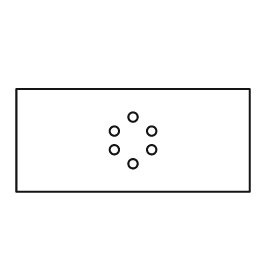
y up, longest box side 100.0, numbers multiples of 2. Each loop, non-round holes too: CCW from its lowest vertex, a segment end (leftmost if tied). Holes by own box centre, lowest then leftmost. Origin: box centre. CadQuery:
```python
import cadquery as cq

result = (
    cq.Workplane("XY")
    .moveTo(-50.0, -22.0)
    .lineTo(50.0, -22.0)
    .lineTo(50.0, 22.0)
    .lineTo(-50.0, 22.0)
    .close()
    .moveTo(0.0, -10.0)
    .circle(2.0)
    .moveTo(-8.0, -4.0)
    .circle(2.0)
    .moveTo(8.0, -4.0)
    .circle(2.0)
    .moveTo(-8.0, 4.0)
    .circle(2.0)
    .moveTo(8.0, 4.0)
    .circle(2.0)
    .moveTo(0.0, 10.0)
    .circle(2.0)
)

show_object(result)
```